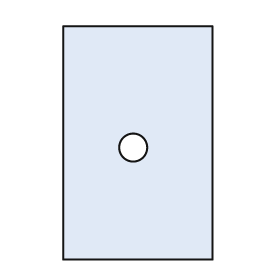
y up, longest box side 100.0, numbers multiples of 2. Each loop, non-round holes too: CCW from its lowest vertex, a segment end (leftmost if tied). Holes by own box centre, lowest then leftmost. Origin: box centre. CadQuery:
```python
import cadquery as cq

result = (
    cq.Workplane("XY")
    .moveTo(-32.0, -50.0)
    .lineTo(32.0, -50.0)
    .lineTo(32.0, 50.0)
    .lineTo(-32.0, 50.0)
    .close()
    .moveTo(-2.0, -2.0)
    .circle(6.0)
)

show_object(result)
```